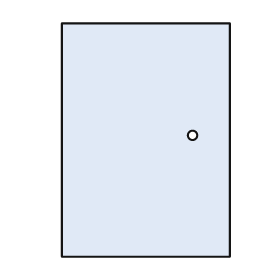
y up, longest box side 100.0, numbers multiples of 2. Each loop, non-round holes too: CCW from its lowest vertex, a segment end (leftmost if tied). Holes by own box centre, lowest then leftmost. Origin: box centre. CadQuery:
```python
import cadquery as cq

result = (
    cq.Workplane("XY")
    .moveTo(-36.0, -50.0)
    .lineTo(36.0, -50.0)
    .lineTo(36.0, 50.0)
    .lineTo(-36.0, 50.0)
    .close()
    .moveTo(20.0, 2.0)
    .circle(2.0)
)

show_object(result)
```